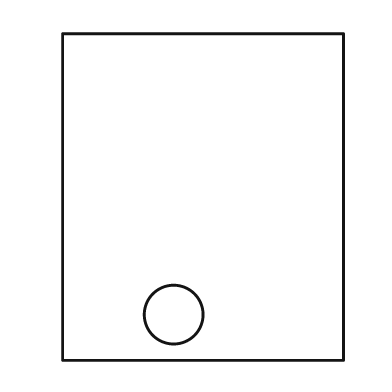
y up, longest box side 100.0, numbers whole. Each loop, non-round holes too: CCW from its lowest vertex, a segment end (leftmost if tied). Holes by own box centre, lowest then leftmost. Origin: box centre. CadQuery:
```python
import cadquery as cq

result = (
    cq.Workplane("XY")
    .moveTo(-43.0, -50.0)
    .lineTo(43.0, -50.0)
    .lineTo(43.0, 50.0)
    .lineTo(-43.0, 50.0)
    .close()
    .moveTo(-9.0, -36.0)
    .circle(9.0)
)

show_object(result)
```